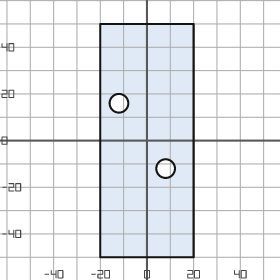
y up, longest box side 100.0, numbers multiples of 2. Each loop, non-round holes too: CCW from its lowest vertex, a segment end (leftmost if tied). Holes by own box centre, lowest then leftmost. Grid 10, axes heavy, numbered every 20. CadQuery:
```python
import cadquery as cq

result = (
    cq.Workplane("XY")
    .moveTo(-20.0, -50.0)
    .lineTo(20.0, -50.0)
    .lineTo(20.0, 50.0)
    .lineTo(-20.0, 50.0)
    .close()
    .moveTo(8.0, -12.0)
    .circle(4.0)
    .moveTo(-12.0, 16.0)
    .circle(4.0)
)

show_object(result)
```